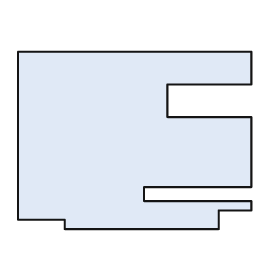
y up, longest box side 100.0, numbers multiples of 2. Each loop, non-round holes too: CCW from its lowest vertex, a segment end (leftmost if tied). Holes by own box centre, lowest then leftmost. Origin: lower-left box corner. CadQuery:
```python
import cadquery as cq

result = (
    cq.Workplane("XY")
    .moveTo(20.0, 0.0)
    .lineTo(86.0, 0.0)
    .lineTo(86.0, 8.0)
    .lineTo(100.0, 8.0)
    .lineTo(100.0, 12.0)
    .lineTo(54.0, 12.0)
    .lineTo(54.0, 18.0)
    .lineTo(100.0, 18.0)
    .lineTo(100.0, 48.0)
    .lineTo(64.0, 48.0)
    .lineTo(64.0, 62.0)
    .lineTo(100.0, 62.0)
    .lineTo(100.0, 76.0)
    .lineTo(0.0, 76.0)
    .lineTo(0.0, 4.0)
    .lineTo(20.0, 4.0)
    .close()
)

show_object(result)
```